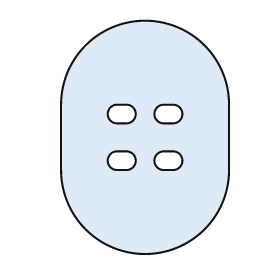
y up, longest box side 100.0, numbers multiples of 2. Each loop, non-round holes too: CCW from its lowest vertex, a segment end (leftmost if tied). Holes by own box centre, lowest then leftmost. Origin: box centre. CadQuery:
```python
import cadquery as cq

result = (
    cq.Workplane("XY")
    .moveTo(-36.0, -14.0)
    .threePointArc((0.0, -50.0), (36.0, -14.0))
    .lineTo(36.0, 14.0)
    .threePointArc((0.0, 50.0), (-36.0, 14.0))
    .close()
    .moveTo(-12.0, -14.0)
    .lineTo(-8.0, -14.0)
    .threePointArc((-4.0, -10.0), (-8.0, -6.0))
    .lineTo(-12.0, -6.0)
    .threePointArc((-16.0, -10.0), (-12.0, -14.0))
    .close()
    .moveTo(8.0, -14.0)
    .lineTo(12.0, -14.0)
    .threePointArc((16.0, -10.0), (12.0, -6.0))
    .lineTo(8.0, -6.0)
    .threePointArc((4.0, -10.0), (8.0, -14.0))
    .close()
    .moveTo(-12.0, 6.0)
    .lineTo(-8.0, 6.0)
    .threePointArc((-4.0, 10.0), (-8.0, 14.0))
    .lineTo(-12.0, 14.0)
    .threePointArc((-16.0, 10.0), (-12.0, 6.0))
    .close()
    .moveTo(8.0, 6.0)
    .lineTo(12.0, 6.0)
    .threePointArc((16.0, 10.0), (12.0, 14.0))
    .lineTo(8.0, 14.0)
    .threePointArc((4.0, 10.0), (8.0, 6.0))
    .close()
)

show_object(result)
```